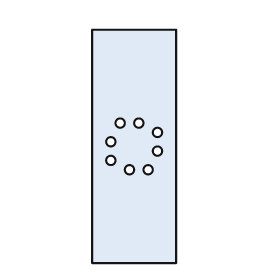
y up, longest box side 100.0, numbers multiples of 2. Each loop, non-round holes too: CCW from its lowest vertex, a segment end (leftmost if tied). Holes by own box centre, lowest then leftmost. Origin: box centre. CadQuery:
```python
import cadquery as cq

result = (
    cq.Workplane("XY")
    .moveTo(-18.0, -50.0)
    .lineTo(18.0, -50.0)
    .lineTo(18.0, 50.0)
    .lineTo(-18.0, 50.0)
    .close()
    .moveTo(-2.0, -10.0)
    .circle(2.0)
    .moveTo(6.0, -10.0)
    .circle(2.0)
    .moveTo(-10.0, -6.0)
    .circle(2.0)
    .moveTo(10.0, -2.0)
    .circle(2.0)
    .moveTo(-10.0, 2.0)
    .circle(2.0)
    .moveTo(10.0, 6.0)
    .circle(2.0)
    .moveTo(-6.0, 10.0)
    .circle(2.0)
    .moveTo(2.0, 10.0)
    .circle(2.0)
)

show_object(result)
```